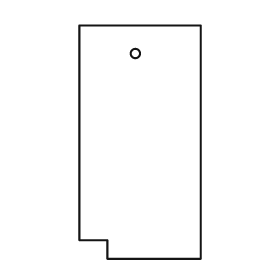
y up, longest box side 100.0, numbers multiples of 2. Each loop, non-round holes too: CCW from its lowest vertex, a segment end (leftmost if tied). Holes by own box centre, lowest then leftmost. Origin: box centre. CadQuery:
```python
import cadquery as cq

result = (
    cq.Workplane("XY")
    .moveTo(-14.0, -50.0)
    .lineTo(26.0, -50.0)
    .lineTo(26.0, 50.0)
    .lineTo(-26.0, 50.0)
    .lineTo(-26.0, -42.0)
    .lineTo(-14.0, -42.0)
    .close()
    .moveTo(-2.0, 38.0)
    .circle(2.0)
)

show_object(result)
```